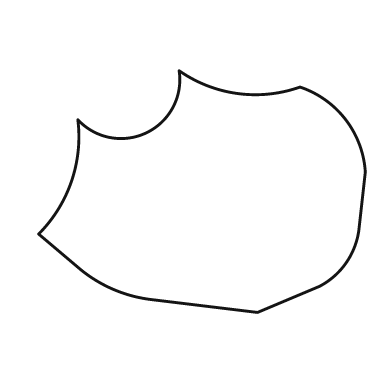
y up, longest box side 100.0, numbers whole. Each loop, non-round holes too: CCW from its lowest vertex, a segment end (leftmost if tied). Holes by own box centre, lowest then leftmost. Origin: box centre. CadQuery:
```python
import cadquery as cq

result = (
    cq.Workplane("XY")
    .moveTo(17.0, -37.0)
    .lineTo(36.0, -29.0)
    .threePointArc((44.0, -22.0), (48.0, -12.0))
    .lineTo(50.0, 6.0)
    .threePointArc((44.0, 22.0), (30.0, 32.0))
    .threePointArc((11.0, 30.0), (-7.0, 37.0))
    .threePointArc((-17.0, 18.0), (-38.0, 22.0))
    .threePointArc((-40.0, 3.0), (-50.0, -13.0))
    .lineTo(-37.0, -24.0)
    .threePointArc((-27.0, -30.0), (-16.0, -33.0))
    .close()
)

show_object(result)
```